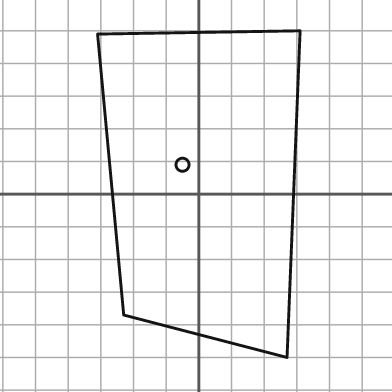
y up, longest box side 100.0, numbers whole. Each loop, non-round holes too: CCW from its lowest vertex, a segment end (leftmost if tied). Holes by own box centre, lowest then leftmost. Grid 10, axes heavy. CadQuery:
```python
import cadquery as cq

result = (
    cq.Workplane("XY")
    .moveTo(27.0, -50.0)
    .lineTo(31.0, 50.0)
    .lineTo(-31.0, 49.0)
    .lineTo(-23.0, -37.0)
    .close()
    .moveTo(-5.0, 9.0)
    .circle(2.0)
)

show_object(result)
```